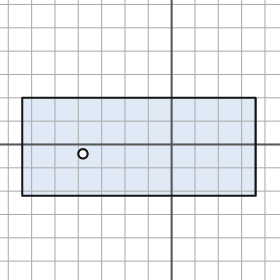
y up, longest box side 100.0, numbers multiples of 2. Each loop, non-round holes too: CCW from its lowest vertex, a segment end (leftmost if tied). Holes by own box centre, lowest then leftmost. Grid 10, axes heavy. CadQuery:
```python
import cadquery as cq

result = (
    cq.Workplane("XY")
    .moveTo(-64.0, -22.0)
    .lineTo(36.0, -22.0)
    .lineTo(36.0, 20.0)
    .lineTo(-64.0, 20.0)
    .close()
    .moveTo(-38.0, -4.0)
    .circle(2.0)
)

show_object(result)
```